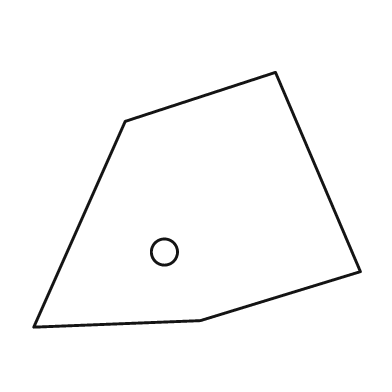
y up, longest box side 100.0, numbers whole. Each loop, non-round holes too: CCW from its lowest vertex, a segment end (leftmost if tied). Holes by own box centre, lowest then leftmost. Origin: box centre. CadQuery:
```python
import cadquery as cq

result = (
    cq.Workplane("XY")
    .moveTo(-50.0, -39.0)
    .lineTo(1.0, -37.0)
    .lineTo(50.0, -22.0)
    .lineTo(24.0, 39.0)
    .lineTo(-22.0, 24.0)
    .close()
    .moveTo(-10.0, -16.0)
    .circle(4.0)
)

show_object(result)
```